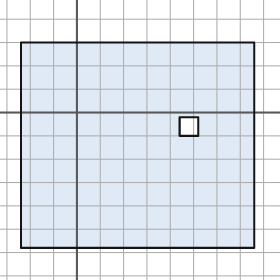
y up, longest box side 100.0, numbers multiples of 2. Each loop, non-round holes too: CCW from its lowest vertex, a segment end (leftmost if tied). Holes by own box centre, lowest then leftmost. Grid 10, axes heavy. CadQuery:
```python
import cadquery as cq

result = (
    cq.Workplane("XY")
    .moveTo(-24.0, -58.0)
    .lineTo(76.0, -58.0)
    .lineTo(76.0, 30.0)
    .lineTo(-24.0, 30.0)
    .close()
    .moveTo(44.0, -10.0)
    .lineTo(52.0, -10.0)
    .lineTo(52.0, -2.0)
    .lineTo(44.0, -2.0)
    .close()
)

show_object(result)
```